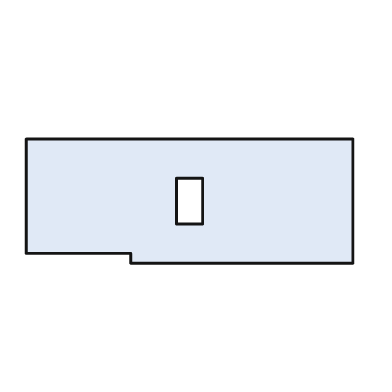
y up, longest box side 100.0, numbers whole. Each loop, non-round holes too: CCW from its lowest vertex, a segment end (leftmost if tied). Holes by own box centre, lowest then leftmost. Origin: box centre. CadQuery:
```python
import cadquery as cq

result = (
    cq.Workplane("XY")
    .moveTo(-18.0, -19.0)
    .lineTo(50.0, -19.0)
    .lineTo(50.0, 19.0)
    .lineTo(-50.0, 19.0)
    .lineTo(-50.0, -16.0)
    .lineTo(-18.0, -16.0)
    .close()
    .moveTo(-4.0, -7.0)
    .lineTo(4.0, -7.0)
    .lineTo(4.0, 7.0)
    .lineTo(-4.0, 7.0)
    .close()
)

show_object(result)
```